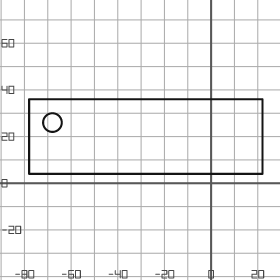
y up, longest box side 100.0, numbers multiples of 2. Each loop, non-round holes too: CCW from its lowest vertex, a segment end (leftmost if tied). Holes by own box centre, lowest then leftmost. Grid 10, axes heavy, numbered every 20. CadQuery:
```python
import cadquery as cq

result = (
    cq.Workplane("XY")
    .moveTo(-78.0, 4.0)
    .lineTo(22.0, 4.0)
    .lineTo(22.0, 36.0)
    .lineTo(-78.0, 36.0)
    .close()
    .moveTo(-68.0, 26.0)
    .circle(4.0)
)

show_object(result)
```